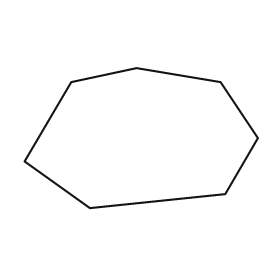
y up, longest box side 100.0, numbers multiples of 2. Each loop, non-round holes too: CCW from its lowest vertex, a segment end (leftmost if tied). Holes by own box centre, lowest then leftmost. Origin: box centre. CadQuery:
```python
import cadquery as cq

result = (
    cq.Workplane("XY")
    .moveTo(-22.0, -30.0)
    .lineTo(36.0, -24.0)
    .lineTo(50.0, 0.0)
    .lineTo(34.0, 24.0)
    .lineTo(-2.0, 30.0)
    .lineTo(-30.0, 24.0)
    .lineTo(-50.0, -10.0)
    .close()
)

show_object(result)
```